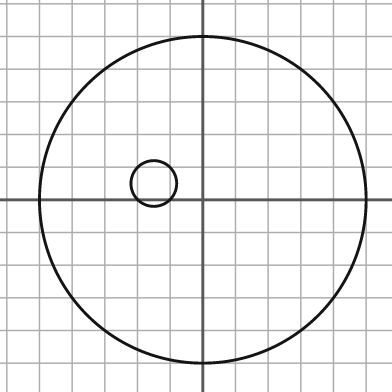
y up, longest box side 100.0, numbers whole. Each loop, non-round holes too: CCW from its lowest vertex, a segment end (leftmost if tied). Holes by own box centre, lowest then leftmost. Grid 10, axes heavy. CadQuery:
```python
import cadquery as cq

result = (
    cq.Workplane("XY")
    .moveTo(0.0, 0.0)
    .circle(50.0)
    .moveTo(-15.0, 5.0)
    .circle(7.0)
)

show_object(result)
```